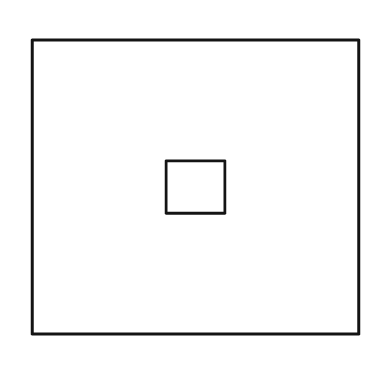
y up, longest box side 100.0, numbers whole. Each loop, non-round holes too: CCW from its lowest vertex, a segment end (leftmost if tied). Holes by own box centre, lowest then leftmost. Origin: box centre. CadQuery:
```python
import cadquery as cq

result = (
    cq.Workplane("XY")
    .moveTo(-50.0, -45.0)
    .lineTo(50.0, -45.0)
    .lineTo(50.0, 45.0)
    .lineTo(-50.0, 45.0)
    .close()
    .moveTo(-9.0, -8.0)
    .lineTo(9.0, -8.0)
    .lineTo(9.0, 8.0)
    .lineTo(-9.0, 8.0)
    .close()
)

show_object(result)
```